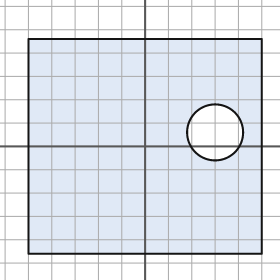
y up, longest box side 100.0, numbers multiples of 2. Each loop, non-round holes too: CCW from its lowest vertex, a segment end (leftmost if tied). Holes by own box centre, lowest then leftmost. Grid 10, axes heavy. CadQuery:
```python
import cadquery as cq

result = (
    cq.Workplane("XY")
    .moveTo(-50.0, -46.0)
    .lineTo(50.0, -46.0)
    .lineTo(50.0, 46.0)
    .lineTo(-50.0, 46.0)
    .close()
    .moveTo(30.0, 6.0)
    .circle(12.0)
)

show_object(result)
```